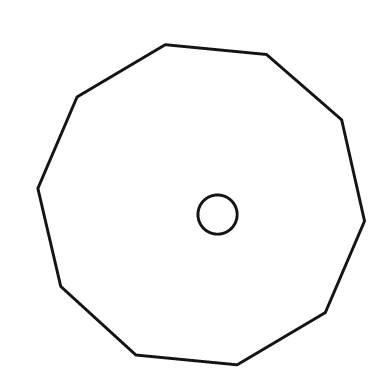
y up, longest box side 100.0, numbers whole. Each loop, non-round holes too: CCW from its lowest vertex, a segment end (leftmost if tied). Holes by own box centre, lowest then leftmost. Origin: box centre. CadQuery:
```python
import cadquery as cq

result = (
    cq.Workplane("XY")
    .moveTo(11.0, -49.0)
    .lineTo(38.0, -33.0)
    .lineTo(50.0, -5.0)
    .lineTo(43.0, 26.0)
    .lineTo(20.0, 46.0)
    .lineTo(-11.0, 49.0)
    .lineTo(-38.0, 33.0)
    .lineTo(-50.0, 5.0)
    .lineTo(-43.0, -25.0)
    .lineTo(-20.0, -46.0)
    .close()
    .moveTo(5.0, -3.0)
    .circle(6.0)
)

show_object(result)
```